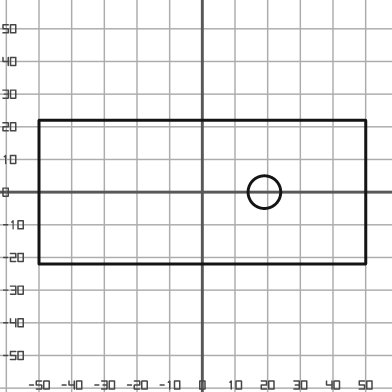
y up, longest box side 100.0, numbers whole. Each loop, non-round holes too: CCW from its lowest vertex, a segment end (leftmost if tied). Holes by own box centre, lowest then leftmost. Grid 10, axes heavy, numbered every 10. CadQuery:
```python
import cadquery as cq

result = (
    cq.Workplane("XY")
    .moveTo(-50.0, -22.0)
    .lineTo(50.0, -22.0)
    .lineTo(50.0, 22.0)
    .lineTo(-50.0, 22.0)
    .close()
    .moveTo(19.0, 0.0)
    .circle(5.0)
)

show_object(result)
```